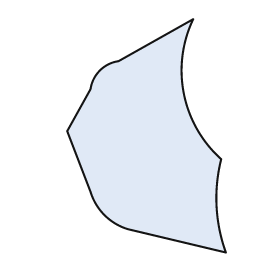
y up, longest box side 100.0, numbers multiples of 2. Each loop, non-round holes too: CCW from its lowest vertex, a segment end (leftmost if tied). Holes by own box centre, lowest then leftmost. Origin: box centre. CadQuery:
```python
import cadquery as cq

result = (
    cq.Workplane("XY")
    .moveTo(34.0, -50.0)
    .threePointArc((30.0, -30.0), (32.0, -10.0))
    .threePointArc((16.0, 18.0), (20.0, 50.0))
    .lineTo(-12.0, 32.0)
    .threePointArc((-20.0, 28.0), (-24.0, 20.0))
    .lineTo(-34.0, 2.0)
    .lineTo(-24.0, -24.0)
    .threePointArc((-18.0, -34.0), (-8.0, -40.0))
    .close()
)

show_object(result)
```